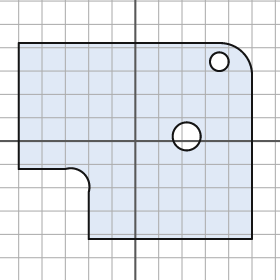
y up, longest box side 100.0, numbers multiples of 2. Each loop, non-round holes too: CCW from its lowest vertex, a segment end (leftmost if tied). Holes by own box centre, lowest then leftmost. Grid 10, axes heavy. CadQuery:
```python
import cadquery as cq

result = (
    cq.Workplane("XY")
    .moveTo(-20.0, -42.0)
    .lineTo(50.0, -42.0)
    .lineTo(50.0, 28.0)
    .threePointArc((46.0, 38.0), (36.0, 42.0))
    .lineTo(-50.0, 42.0)
    .lineTo(-50.0, -12.0)
    .lineTo(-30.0, -12.0)
    .threePointArc((-22.0, -14.0), (-20.0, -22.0))
    .close()
    .moveTo(22.0, 2.0)
    .circle(6.0)
    .moveTo(36.0, 34.0)
    .circle(4.0)
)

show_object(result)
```